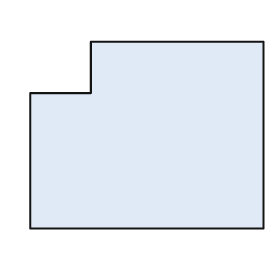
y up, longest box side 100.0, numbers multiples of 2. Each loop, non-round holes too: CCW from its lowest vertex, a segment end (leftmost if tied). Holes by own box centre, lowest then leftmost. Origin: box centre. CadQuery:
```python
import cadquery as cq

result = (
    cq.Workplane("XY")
    .moveTo(-50.0, -40.0)
    .lineTo(50.0, -40.0)
    .lineTo(50.0, 40.0)
    .lineTo(-24.0, 40.0)
    .lineTo(-24.0, 18.0)
    .lineTo(-50.0, 18.0)
    .close()
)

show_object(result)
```